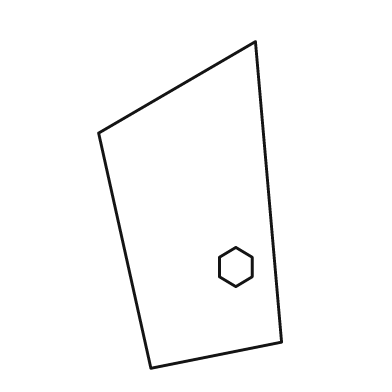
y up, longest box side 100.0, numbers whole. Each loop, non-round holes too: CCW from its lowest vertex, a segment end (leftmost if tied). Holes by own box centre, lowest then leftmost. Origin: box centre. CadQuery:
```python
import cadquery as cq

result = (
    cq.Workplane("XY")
    .moveTo(-12.0, -50.0)
    .lineTo(28.0, -42.0)
    .lineTo(20.0, 50.0)
    .lineTo(-28.0, 22.0)
    .close()
    .moveTo(14.0, -25.0)
    .lineTo(19.0, -22.0)
    .lineTo(19.0, -16.0)
    .lineTo(14.0, -13.0)
    .lineTo(9.0, -16.0)
    .lineTo(9.0, -22.0)
    .close()
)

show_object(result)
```